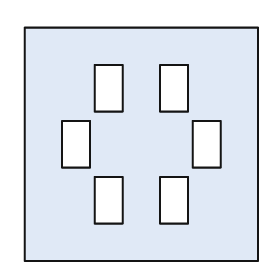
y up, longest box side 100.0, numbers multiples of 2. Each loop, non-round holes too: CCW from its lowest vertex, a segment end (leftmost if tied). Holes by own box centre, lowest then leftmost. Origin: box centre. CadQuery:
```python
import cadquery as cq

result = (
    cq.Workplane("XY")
    .moveTo(-50.0, -50.0)
    .lineTo(50.0, -50.0)
    .lineTo(50.0, 50.0)
    .lineTo(-50.0, 50.0)
    .close()
    .moveTo(-20.0, -34.0)
    .lineTo(-8.0, -34.0)
    .lineTo(-8.0, -14.0)
    .lineTo(-20.0, -14.0)
    .close()
    .moveTo(8.0, -34.0)
    .lineTo(20.0, -34.0)
    .lineTo(20.0, -14.0)
    .lineTo(8.0, -14.0)
    .close()
    .moveTo(-34.0, -10.0)
    .lineTo(-22.0, -10.0)
    .lineTo(-22.0, 10.0)
    .lineTo(-34.0, 10.0)
    .close()
    .moveTo(22.0, -10.0)
    .lineTo(34.0, -10.0)
    .lineTo(34.0, 10.0)
    .lineTo(22.0, 10.0)
    .close()
    .moveTo(-20.0, 14.0)
    .lineTo(-8.0, 14.0)
    .lineTo(-8.0, 34.0)
    .lineTo(-20.0, 34.0)
    .close()
    .moveTo(8.0, 14.0)
    .lineTo(20.0, 14.0)
    .lineTo(20.0, 34.0)
    .lineTo(8.0, 34.0)
    .close()
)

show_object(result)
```